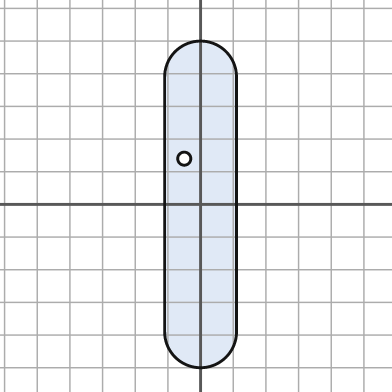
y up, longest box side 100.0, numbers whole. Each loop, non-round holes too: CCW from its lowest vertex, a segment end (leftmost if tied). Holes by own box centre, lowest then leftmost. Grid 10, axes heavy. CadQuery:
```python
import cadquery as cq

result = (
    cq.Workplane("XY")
    .moveTo(-11.0, -39.0)
    .threePointArc((0.0, -50.0), (11.0, -39.0))
    .lineTo(11.0, 39.0)
    .threePointArc((0.0, 50.0), (-11.0, 39.0))
    .close()
    .moveTo(-5.0, 14.0)
    .circle(2.0)
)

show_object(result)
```